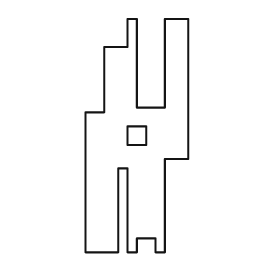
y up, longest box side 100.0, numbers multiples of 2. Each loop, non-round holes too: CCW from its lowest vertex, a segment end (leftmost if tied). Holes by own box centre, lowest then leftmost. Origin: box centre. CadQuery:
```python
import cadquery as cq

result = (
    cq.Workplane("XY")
    .moveTo(-22.0, -50.0)
    .lineTo(-8.0, -50.0)
    .lineTo(-8.0, -14.0)
    .lineTo(-4.0, -14.0)
    .lineTo(-4.0, -50.0)
    .lineTo(0.0, -50.0)
    .lineTo(0.0, -44.0)
    .lineTo(8.0, -44.0)
    .lineTo(8.0, -50.0)
    .lineTo(12.0, -50.0)
    .lineTo(12.0, -10.0)
    .lineTo(22.0, -10.0)
    .lineTo(22.0, 50.0)
    .lineTo(12.0, 50.0)
    .lineTo(12.0, 12.0)
    .lineTo(0.0, 12.0)
    .lineTo(0.0, 50.0)
    .lineTo(-4.0, 50.0)
    .lineTo(-4.0, 38.0)
    .lineTo(-14.0, 38.0)
    .lineTo(-14.0, 10.0)
    .lineTo(-22.0, 10.0)
    .close()
    .moveTo(-4.0, -4.0)
    .lineTo(4.0, -4.0)
    .lineTo(4.0, 4.0)
    .lineTo(-4.0, 4.0)
    .close()
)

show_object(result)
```